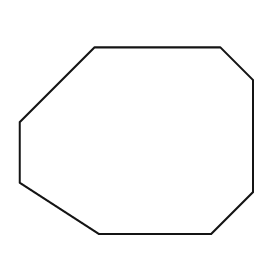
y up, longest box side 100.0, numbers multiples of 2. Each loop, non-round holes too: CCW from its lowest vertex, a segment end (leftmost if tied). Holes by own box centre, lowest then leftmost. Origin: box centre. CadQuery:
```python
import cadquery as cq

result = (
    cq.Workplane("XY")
    .moveTo(-16.0, -40.0)
    .lineTo(32.0, -40.0)
    .lineTo(50.0, -22.0)
    .lineTo(50.0, 26.0)
    .lineTo(36.0, 40.0)
    .lineTo(-18.0, 40.0)
    .lineTo(-50.0, 8.0)
    .lineTo(-50.0, -18.0)
    .close()
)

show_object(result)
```